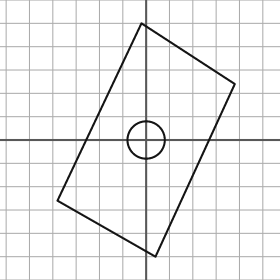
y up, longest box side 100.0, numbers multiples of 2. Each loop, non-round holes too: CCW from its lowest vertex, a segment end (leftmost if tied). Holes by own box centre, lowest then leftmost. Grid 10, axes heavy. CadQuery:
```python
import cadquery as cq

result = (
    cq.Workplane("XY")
    .moveTo(4.0, -50.0)
    .lineTo(38.0, 24.0)
    .lineTo(-2.0, 50.0)
    .lineTo(-38.0, -26.0)
    .close()
    .moveTo(0.0, 0.0)
    .circle(8.0)
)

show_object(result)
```